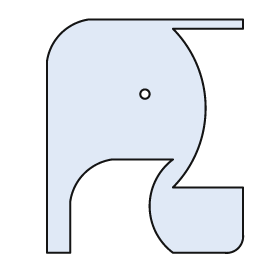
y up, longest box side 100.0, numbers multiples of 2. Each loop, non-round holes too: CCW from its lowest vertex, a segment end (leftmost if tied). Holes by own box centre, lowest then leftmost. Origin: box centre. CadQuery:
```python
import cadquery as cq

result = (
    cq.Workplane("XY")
    .moveTo(-42.0, -50.0)
    .lineTo(-32.0, -50.0)
    .lineTo(-32.0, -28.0)
    .threePointArc((-26.0, -16.0), (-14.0, -10.0))
    .lineTo(12.0, -10.0)
    .threePointArc((2.0, -30.0), (12.0, -50.0))
    .lineTo(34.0, -50.0)
    .threePointArc((40.0, -48.0), (42.0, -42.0))
    .lineTo(42.0, -22.0)
    .lineTo(12.0, -22.0)
    .threePointArc((26.0, 12.0), (12.0, 46.0))
    .lineTo(42.0, 46.0)
    .lineTo(42.0, 50.0)
    .lineTo(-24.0, 50.0)
    .threePointArc((-36.0, 44.0), (-42.0, 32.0))
    .close()
    .moveTo(0.0, 18.0)
    .circle(2.0)
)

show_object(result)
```